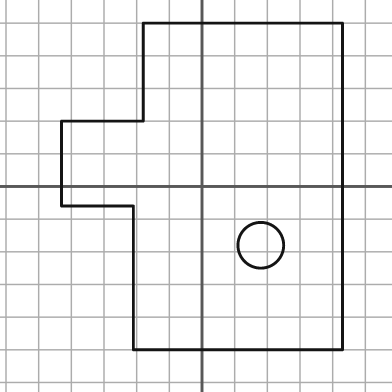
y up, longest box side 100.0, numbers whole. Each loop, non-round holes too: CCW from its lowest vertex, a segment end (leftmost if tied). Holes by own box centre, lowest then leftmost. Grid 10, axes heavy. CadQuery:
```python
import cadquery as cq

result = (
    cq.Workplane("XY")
    .moveTo(-21.0, -50.0)
    .lineTo(43.0, -50.0)
    .lineTo(43.0, 50.0)
    .lineTo(-18.0, 50.0)
    .lineTo(-18.0, 20.0)
    .lineTo(-43.0, 20.0)
    .lineTo(-43.0, -6.0)
    .lineTo(-21.0, -6.0)
    .close()
    .moveTo(18.0, -18.0)
    .circle(7.0)
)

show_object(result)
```